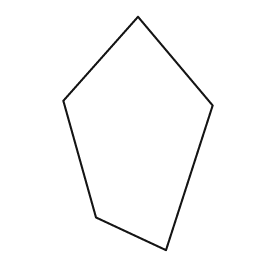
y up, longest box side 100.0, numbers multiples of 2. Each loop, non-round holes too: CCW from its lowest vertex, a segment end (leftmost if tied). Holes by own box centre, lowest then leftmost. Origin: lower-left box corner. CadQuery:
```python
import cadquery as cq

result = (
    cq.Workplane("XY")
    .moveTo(44.0, 0.0)
    .lineTo(64.0, 62.0)
    .lineTo(32.0, 100.0)
    .lineTo(0.0, 64.0)
    .lineTo(14.0, 14.0)
    .close()
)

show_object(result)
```